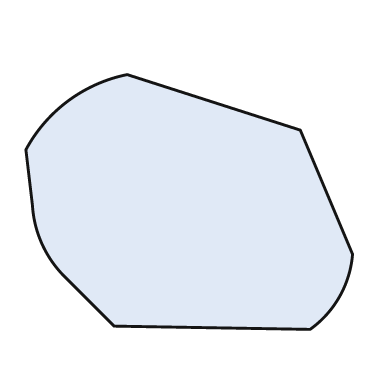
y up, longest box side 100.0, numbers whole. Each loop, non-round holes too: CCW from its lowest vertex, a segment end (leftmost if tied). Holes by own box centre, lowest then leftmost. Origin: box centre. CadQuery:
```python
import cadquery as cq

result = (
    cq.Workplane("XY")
    .moveTo(37.0, -39.0)
    .threePointArc((46.0, -29.0), (50.0, -16.0))
    .lineTo(34.0, 22.0)
    .lineTo(-19.0, 39.0)
    .threePointArc((-37.0, 31.0), (-50.0, 16.0))
    .lineTo(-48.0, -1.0)
    .threePointArc((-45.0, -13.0), (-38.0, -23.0))
    .lineTo(-23.0, -38.0)
    .close()
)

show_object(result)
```